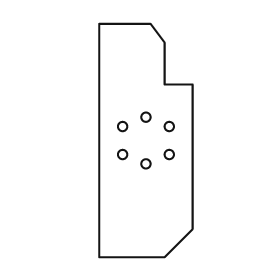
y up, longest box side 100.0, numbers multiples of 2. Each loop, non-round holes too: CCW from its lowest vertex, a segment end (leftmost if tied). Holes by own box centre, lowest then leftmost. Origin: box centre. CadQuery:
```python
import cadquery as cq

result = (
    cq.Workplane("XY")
    .moveTo(-20.0, -50.0)
    .lineTo(8.0, -50.0)
    .lineTo(20.0, -38.0)
    .lineTo(20.0, 24.0)
    .lineTo(8.0, 24.0)
    .lineTo(8.0, 42.0)
    .lineTo(2.0, 50.0)
    .lineTo(-20.0, 50.0)
    .close()
    .moveTo(0.0, -10.0)
    .circle(2.0)
    .moveTo(-10.0, -6.0)
    .circle(2.0)
    .moveTo(10.0, -6.0)
    .circle(2.0)
    .moveTo(-10.0, 6.0)
    .circle(2.0)
    .moveTo(10.0, 6.0)
    .circle(2.0)
    .moveTo(0.0, 10.0)
    .circle(2.0)
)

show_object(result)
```